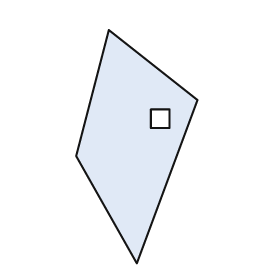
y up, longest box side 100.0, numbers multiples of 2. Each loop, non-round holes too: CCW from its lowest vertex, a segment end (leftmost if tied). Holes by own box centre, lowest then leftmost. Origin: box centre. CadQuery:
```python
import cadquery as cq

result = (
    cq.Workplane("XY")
    .moveTo(0.0, -50.0)
    .lineTo(26.0, 20.0)
    .lineTo(-12.0, 50.0)
    .lineTo(-26.0, -4.0)
    .close()
    .moveTo(6.0, 8.0)
    .lineTo(14.0, 8.0)
    .lineTo(14.0, 16.0)
    .lineTo(6.0, 16.0)
    .close()
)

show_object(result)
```